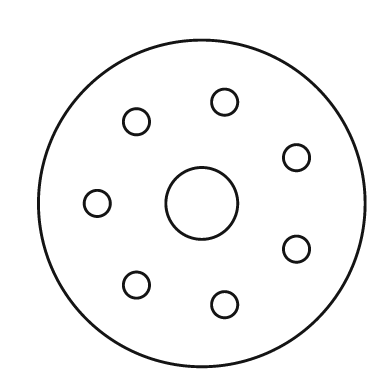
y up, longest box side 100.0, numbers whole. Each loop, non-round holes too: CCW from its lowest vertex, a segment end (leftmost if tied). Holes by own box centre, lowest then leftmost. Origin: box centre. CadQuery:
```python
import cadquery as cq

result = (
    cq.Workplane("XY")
    .moveTo(0.0, 0.0)
    .circle(50.0)
    .moveTo(7.0, -31.0)
    .circle(4.0)
    .moveTo(-20.0, -25.0)
    .circle(4.0)
    .moveTo(29.0, -14.0)
    .circle(4.0)
    .moveTo(-32.0, 0.0)
    .circle(4.0)
    .moveTo(0.0, 0.0)
    .circle(11.0)
    .moveTo(29.0, 14.0)
    .circle(4.0)
    .moveTo(-20.0, 25.0)
    .circle(4.0)
    .moveTo(7.0, 31.0)
    .circle(4.0)
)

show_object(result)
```